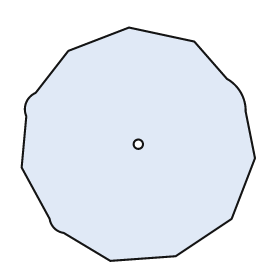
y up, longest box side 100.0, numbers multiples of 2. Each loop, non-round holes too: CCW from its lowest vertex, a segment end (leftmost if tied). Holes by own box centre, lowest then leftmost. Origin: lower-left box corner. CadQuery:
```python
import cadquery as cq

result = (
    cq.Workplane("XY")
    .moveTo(38.0, 0.0)
    .lineTo(66.0, 2.0)
    .lineTo(90.0, 18.0)
    .lineTo(100.0, 44.0)
    .lineTo(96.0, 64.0)
    .threePointArc((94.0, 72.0), (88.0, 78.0))
    .lineTo(74.0, 94.0)
    .lineTo(46.0, 100.0)
    .lineTo(20.0, 90.0)
    .lineTo(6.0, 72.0)
    .threePointArc((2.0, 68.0), (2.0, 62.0))
    .lineTo(0.0, 40.0)
    .lineTo(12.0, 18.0)
    .threePointArc((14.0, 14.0), (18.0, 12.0))
    .close()
    .moveTo(50.0, 50.0)
    .circle(2.0)
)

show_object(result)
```